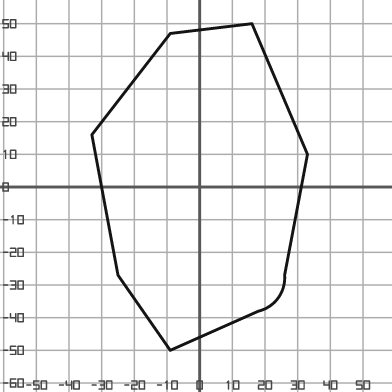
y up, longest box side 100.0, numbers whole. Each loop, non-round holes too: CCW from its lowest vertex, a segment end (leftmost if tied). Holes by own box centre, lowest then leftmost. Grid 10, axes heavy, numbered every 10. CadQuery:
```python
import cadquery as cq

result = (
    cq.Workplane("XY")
    .moveTo(-9.0, -50.0)
    .lineTo(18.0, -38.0)
    .threePointArc((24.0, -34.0), (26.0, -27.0))
    .lineTo(33.0, 10.0)
    .lineTo(16.0, 50.0)
    .lineTo(-9.0, 47.0)
    .lineTo(-33.0, 16.0)
    .lineTo(-25.0, -27.0)
    .close()
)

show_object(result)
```